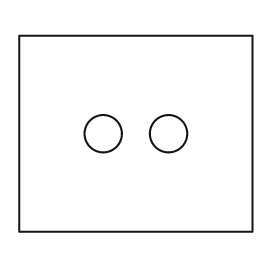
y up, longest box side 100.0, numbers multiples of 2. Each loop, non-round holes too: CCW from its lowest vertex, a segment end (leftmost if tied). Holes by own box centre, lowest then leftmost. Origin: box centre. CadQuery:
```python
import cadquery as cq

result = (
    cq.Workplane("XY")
    .moveTo(-50.0, -42.0)
    .lineTo(50.0, -42.0)
    .lineTo(50.0, 42.0)
    .lineTo(-50.0, 42.0)
    .close()
    .moveTo(-14.0, 0.0)
    .circle(8.0)
    .moveTo(14.0, 0.0)
    .circle(8.0)
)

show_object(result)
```